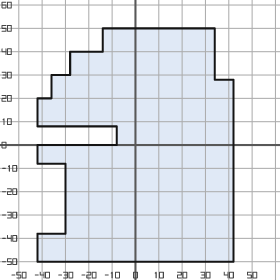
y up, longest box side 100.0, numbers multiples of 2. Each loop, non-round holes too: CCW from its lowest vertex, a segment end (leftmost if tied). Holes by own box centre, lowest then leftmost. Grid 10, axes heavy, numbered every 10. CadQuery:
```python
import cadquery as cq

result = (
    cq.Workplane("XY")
    .moveTo(-42.0, -50.0)
    .lineTo(42.0, -50.0)
    .lineTo(42.0, 28.0)
    .lineTo(34.0, 28.0)
    .lineTo(34.0, 50.0)
    .lineTo(-14.0, 50.0)
    .lineTo(-14.0, 40.0)
    .lineTo(-28.0, 40.0)
    .lineTo(-28.0, 30.0)
    .lineTo(-36.0, 30.0)
    .lineTo(-36.0, 20.0)
    .lineTo(-42.0, 20.0)
    .lineTo(-42.0, 8.0)
    .lineTo(-8.0, 8.0)
    .lineTo(-8.0, 0.0)
    .lineTo(-42.0, 0.0)
    .lineTo(-42.0, -8.0)
    .lineTo(-30.0, -8.0)
    .lineTo(-30.0, -38.0)
    .lineTo(-42.0, -38.0)
    .close()
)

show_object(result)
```